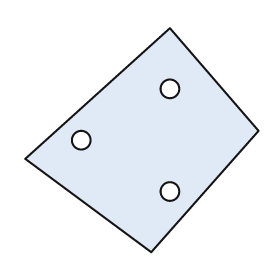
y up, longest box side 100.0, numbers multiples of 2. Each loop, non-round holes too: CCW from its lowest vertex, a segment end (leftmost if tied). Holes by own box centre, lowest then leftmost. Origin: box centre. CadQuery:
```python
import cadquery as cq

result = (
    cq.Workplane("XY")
    .moveTo(4.0, -48.0)
    .lineTo(50.0, 4.0)
    .lineTo(12.0, 48.0)
    .lineTo(-50.0, -8.0)
    .close()
    .moveTo(12.0, -22.0)
    .circle(4.0)
    .moveTo(-26.0, 0.0)
    .circle(4.0)
    .moveTo(12.0, 22.0)
    .circle(4.0)
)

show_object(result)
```